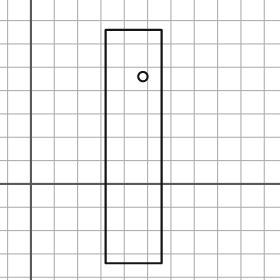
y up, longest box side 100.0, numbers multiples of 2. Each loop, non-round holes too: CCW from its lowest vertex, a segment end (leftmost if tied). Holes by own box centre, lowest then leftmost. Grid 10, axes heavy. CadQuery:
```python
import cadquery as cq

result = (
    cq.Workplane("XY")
    .moveTo(32.0, -34.0)
    .lineTo(56.0, -34.0)
    .lineTo(56.0, 66.0)
    .lineTo(32.0, 66.0)
    .close()
    .moveTo(48.0, 46.0)
    .circle(2.0)
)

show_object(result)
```